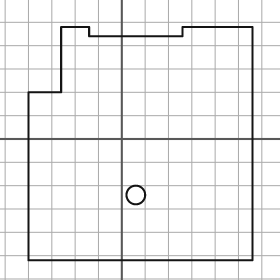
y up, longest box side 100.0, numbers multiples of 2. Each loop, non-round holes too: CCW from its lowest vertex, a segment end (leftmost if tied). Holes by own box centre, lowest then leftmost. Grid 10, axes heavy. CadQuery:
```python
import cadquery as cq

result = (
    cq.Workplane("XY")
    .moveTo(-40.0, -52.0)
    .lineTo(56.0, -52.0)
    .lineTo(56.0, 48.0)
    .lineTo(26.0, 48.0)
    .lineTo(26.0, 44.0)
    .lineTo(-14.0, 44.0)
    .lineTo(-14.0, 48.0)
    .lineTo(-26.0, 48.0)
    .lineTo(-26.0, 20.0)
    .lineTo(-40.0, 20.0)
    .close()
    .moveTo(6.0, -24.0)
    .circle(4.0)
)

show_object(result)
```